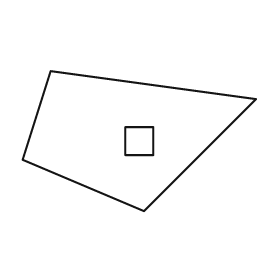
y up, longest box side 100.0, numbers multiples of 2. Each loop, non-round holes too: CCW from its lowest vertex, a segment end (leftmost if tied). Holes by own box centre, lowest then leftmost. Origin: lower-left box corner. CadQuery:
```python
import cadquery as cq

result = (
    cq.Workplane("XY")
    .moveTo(52.0, 0.0)
    .lineTo(100.0, 48.0)
    .lineTo(12.0, 60.0)
    .lineTo(0.0, 22.0)
    .close()
    .moveTo(44.0, 24.0)
    .lineTo(56.0, 24.0)
    .lineTo(56.0, 36.0)
    .lineTo(44.0, 36.0)
    .close()
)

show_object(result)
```